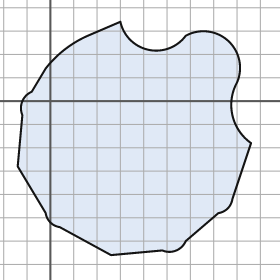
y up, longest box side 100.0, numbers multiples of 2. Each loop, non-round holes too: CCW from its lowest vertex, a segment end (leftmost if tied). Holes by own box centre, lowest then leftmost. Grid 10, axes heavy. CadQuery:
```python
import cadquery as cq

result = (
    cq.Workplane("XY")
    .moveTo(26.0, -66.0)
    .lineTo(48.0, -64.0)
    .threePointArc((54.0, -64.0), (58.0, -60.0))
    .lineTo(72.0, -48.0)
    .threePointArc((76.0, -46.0), (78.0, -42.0))
    .lineTo(86.0, -18.0)
    .threePointArc((78.0, -6.0), (80.0, 8.0))
    .threePointArc((76.0, 26.0), (58.0, 28.0))
    .threePointArc((42.0, 22.0), (30.0, 34.0))
    .lineTo(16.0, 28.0)
    .threePointArc((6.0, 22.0), (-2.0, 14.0))
    .lineTo(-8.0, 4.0)
    .threePointArc((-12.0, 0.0), (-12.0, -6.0))
    .lineTo(-14.0, -28.0)
    .lineTo(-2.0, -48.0)
    .threePointArc((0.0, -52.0), (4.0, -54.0))
    .close()
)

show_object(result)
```